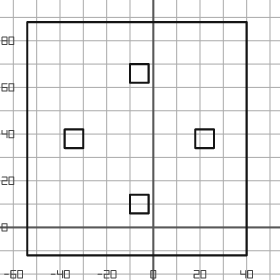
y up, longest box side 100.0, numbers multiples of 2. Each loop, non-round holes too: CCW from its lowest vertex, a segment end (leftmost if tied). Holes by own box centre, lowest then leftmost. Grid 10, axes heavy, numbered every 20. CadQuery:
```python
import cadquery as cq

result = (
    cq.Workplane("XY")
    .moveTo(-54.0, -12.0)
    .lineTo(40.0, -12.0)
    .lineTo(40.0, 88.0)
    .lineTo(-54.0, 88.0)
    .close()
    .moveTo(-10.0, 6.0)
    .lineTo(-2.0, 6.0)
    .lineTo(-2.0, 14.0)
    .lineTo(-10.0, 14.0)
    .close()
    .moveTo(-38.0, 34.0)
    .lineTo(-30.0, 34.0)
    .lineTo(-30.0, 42.0)
    .lineTo(-38.0, 42.0)
    .close()
    .moveTo(18.0, 34.0)
    .lineTo(26.0, 34.0)
    .lineTo(26.0, 42.0)
    .lineTo(18.0, 42.0)
    .close()
    .moveTo(-10.0, 62.0)
    .lineTo(-2.0, 62.0)
    .lineTo(-2.0, 70.0)
    .lineTo(-10.0, 70.0)
    .close()
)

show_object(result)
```